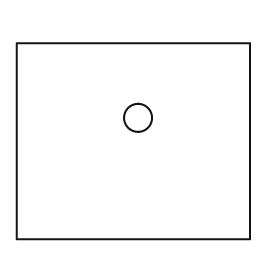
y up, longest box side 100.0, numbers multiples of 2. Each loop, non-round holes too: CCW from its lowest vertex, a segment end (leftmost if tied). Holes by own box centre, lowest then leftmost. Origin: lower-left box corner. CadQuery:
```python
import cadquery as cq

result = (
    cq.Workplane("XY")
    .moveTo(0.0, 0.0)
    .lineTo(100.0, 0.0)
    .lineTo(100.0, 84.0)
    .lineTo(0.0, 84.0)
    .close()
    .moveTo(52.0, 52.0)
    .circle(6.0)
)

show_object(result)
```